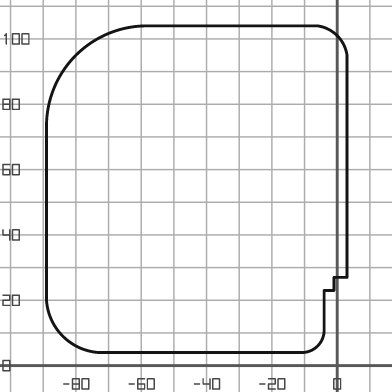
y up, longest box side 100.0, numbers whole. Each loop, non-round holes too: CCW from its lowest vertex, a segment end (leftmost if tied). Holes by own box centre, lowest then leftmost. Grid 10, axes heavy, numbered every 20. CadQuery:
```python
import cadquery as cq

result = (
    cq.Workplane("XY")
    .moveTo(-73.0, 4.0)
    .lineTo(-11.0, 4.0)
    .threePointArc((-6.0, 6.0), (-4.0, 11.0))
    .lineTo(-4.0, 23.0)
    .lineTo(-1.0, 23.0)
    .lineTo(-1.0, 27.0)
    .lineTo(3.0, 27.0)
    .lineTo(3.0, 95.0)
    .threePointArc((0.0, 101.0), (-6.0, 104.0))
    .lineTo(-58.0, 104.0)
    .threePointArc((-80.0, 95.0), (-89.0, 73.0))
    .lineTo(-89.0, 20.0)
    .threePointArc((-84.0, 9.0), (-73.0, 4.0))
    .close()
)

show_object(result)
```